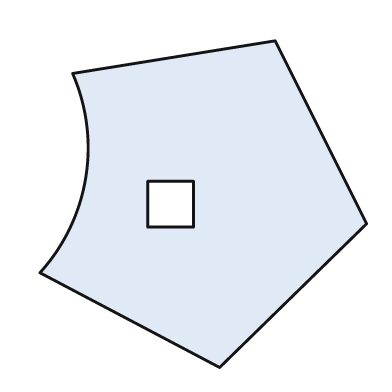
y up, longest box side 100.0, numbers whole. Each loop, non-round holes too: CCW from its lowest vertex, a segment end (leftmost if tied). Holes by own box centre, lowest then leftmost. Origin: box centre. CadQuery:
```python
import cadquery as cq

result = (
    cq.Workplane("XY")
    .moveTo(5.0, -50.0)
    .lineTo(50.0, -6.0)
    .lineTo(22.0, 50.0)
    .lineTo(-40.0, 40.0)
    .threePointArc((-36.0, 8.0), (-50.0, -21.0))
    .close()
    .moveTo(-17.0, -7.0)
    .lineTo(-3.0, -7.0)
    .lineTo(-3.0, 7.0)
    .lineTo(-17.0, 7.0)
    .close()
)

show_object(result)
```